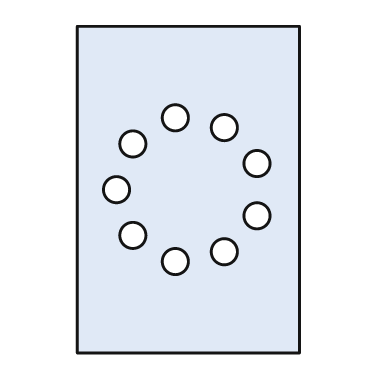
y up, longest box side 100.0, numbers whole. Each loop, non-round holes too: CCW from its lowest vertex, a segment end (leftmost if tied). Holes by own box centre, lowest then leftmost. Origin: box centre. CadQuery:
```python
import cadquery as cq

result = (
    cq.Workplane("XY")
    .moveTo(-34.0, -50.0)
    .lineTo(34.0, -50.0)
    .lineTo(34.0, 50.0)
    .lineTo(-34.0, 50.0)
    .close()
    .moveTo(-4.0, -22.0)
    .circle(4.0)
    .moveTo(11.0, -19.0)
    .circle(4.0)
    .moveTo(-17.0, -14.0)
    .circle(4.0)
    .moveTo(21.0, -8.0)
    .circle(4.0)
    .moveTo(-22.0, 0.0)
    .circle(4.0)
    .moveTo(21.0, 8.0)
    .circle(4.0)
    .moveTo(-17.0, 14.0)
    .circle(4.0)
    .moveTo(11.0, 19.0)
    .circle(4.0)
    .moveTo(-4.0, 22.0)
    .circle(4.0)
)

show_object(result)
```